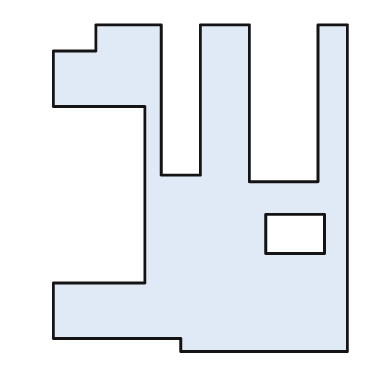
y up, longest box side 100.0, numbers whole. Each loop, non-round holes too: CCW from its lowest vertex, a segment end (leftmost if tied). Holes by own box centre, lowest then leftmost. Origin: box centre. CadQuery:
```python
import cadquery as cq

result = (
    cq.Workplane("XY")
    .moveTo(-6.0, -50.0)
    .lineTo(45.0, -50.0)
    .lineTo(45.0, 50.0)
    .lineTo(36.0, 50.0)
    .lineTo(36.0, 2.0)
    .lineTo(15.0, 2.0)
    .lineTo(15.0, 50.0)
    .lineTo(0.0, 50.0)
    .lineTo(0.0, 4.0)
    .lineTo(-12.0, 4.0)
    .lineTo(-12.0, 50.0)
    .lineTo(-32.0, 50.0)
    .lineTo(-32.0, 42.0)
    .lineTo(-45.0, 42.0)
    .lineTo(-45.0, 25.0)
    .lineTo(-17.0, 25.0)
    .lineTo(-17.0, -29.0)
    .lineTo(-45.0, -29.0)
    .lineTo(-45.0, -46.0)
    .lineTo(-6.0, -46.0)
    .close()
    .moveTo(20.0, -20.0)
    .lineTo(38.0, -20.0)
    .lineTo(38.0, -8.0)
    .lineTo(20.0, -8.0)
    .close()
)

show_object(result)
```